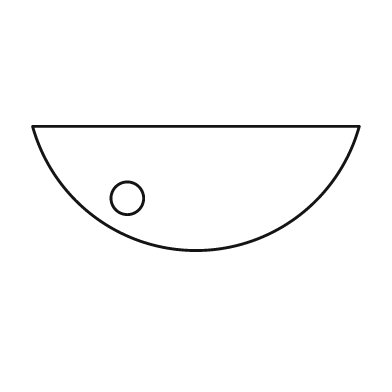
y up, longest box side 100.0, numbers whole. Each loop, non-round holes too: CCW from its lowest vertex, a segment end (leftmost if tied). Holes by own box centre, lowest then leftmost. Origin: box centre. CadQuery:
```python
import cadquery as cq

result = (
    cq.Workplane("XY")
    .moveTo(-50.0, 19.0)
    .threePointArc((0.0, -19.0), (50.0, 19.0))
    .close()
    .moveTo(-21.0, -3.0)
    .circle(5.0)
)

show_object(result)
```